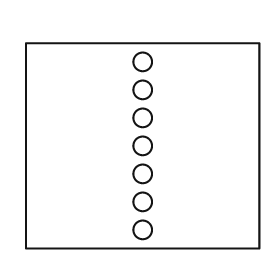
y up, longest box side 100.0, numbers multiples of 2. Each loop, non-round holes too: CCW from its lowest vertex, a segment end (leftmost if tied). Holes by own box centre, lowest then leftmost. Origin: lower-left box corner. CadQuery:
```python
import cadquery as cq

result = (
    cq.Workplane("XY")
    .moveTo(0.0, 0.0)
    .lineTo(100.0, 0.0)
    .lineTo(100.0, 88.0)
    .lineTo(0.0, 88.0)
    .close()
    .moveTo(50.0, 8.0)
    .circle(4.0)
    .moveTo(50.0, 20.0)
    .circle(4.0)
    .moveTo(50.0, 32.0)
    .circle(4.0)
    .moveTo(50.0, 44.0)
    .circle(4.0)
    .moveTo(50.0, 56.0)
    .circle(4.0)
    .moveTo(50.0, 68.0)
    .circle(4.0)
    .moveTo(50.0, 80.0)
    .circle(4.0)
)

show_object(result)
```